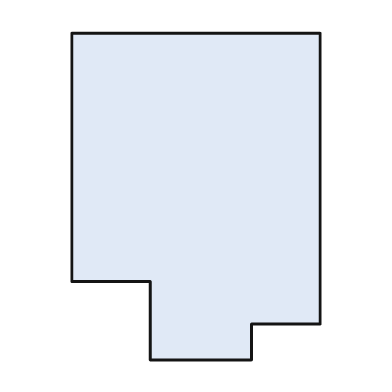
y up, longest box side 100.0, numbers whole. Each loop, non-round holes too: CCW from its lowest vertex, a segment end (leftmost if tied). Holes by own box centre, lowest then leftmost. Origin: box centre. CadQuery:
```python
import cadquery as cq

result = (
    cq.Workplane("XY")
    .moveTo(-14.0, -50.0)
    .lineTo(17.0, -50.0)
    .lineTo(17.0, -39.0)
    .lineTo(38.0, -39.0)
    .lineTo(38.0, 50.0)
    .lineTo(-38.0, 50.0)
    .lineTo(-38.0, -26.0)
    .lineTo(-14.0, -26.0)
    .close()
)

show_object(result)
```